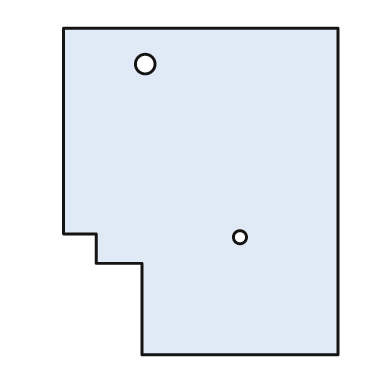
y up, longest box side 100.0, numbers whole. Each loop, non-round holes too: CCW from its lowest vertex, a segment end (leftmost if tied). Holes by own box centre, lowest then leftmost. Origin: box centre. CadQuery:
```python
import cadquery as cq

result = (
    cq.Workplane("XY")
    .moveTo(-18.0, -50.0)
    .lineTo(42.0, -50.0)
    .lineTo(42.0, 50.0)
    .lineTo(-42.0, 50.0)
    .lineTo(-42.0, -13.0)
    .lineTo(-32.0, -13.0)
    .lineTo(-32.0, -22.0)
    .lineTo(-18.0, -22.0)
    .close()
    .moveTo(12.0, -14.0)
    .circle(2.0)
    .moveTo(-17.0, 39.0)
    .circle(3.0)
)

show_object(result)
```